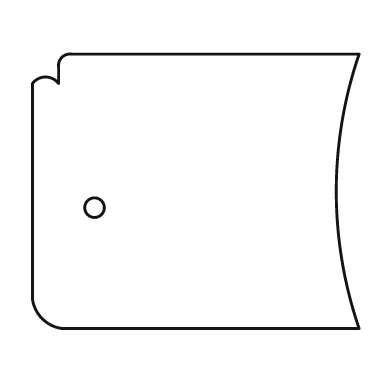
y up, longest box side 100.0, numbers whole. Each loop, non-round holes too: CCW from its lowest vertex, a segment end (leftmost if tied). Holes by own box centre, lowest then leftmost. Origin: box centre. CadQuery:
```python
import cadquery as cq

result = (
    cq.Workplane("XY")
    .moveTo(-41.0, -42.0)
    .lineTo(50.0, -42.0)
    .threePointArc((43.0, 0.0), (50.0, 42.0))
    .lineTo(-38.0, 42.0)
    .threePointArc((-41.0, 41.0), (-42.0, 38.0))
    .lineTo(-42.0, 33.0)
    .threePointArc((-46.0, 35.0), (-50.0, 33.0))
    .lineTo(-50.0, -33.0)
    .threePointArc((-47.0, -39.0), (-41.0, -42.0))
    .close()
    .moveTo(-31.0, -5.0)
    .circle(3.0)
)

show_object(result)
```